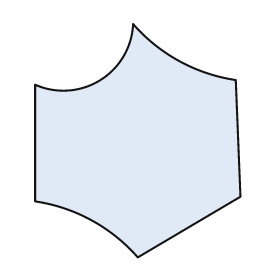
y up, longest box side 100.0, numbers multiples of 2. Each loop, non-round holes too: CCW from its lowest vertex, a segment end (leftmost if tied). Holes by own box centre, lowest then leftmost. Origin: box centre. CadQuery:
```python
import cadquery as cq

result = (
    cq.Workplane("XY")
    .moveTo(0.0, -50.0)
    .lineTo(44.0, -24.0)
    .lineTo(42.0, 26.0)
    .threePointArc((18.0, 34.0), (-2.0, 50.0))
    .threePointArc((-16.0, 26.0), (-44.0, 24.0))
    .lineTo(-44.0, -26.0)
    .threePointArc((-20.0, -34.0), (0.0, -50.0))
    .close()
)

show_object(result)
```